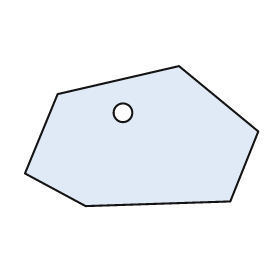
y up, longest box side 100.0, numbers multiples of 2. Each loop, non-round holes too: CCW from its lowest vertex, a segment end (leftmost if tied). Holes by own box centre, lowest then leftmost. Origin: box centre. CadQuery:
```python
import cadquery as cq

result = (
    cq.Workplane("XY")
    .moveTo(-24.0, -30.0)
    .lineTo(38.0, -28.0)
    .lineTo(50.0, 2.0)
    .lineTo(16.0, 30.0)
    .lineTo(-36.0, 18.0)
    .lineTo(-50.0, -16.0)
    .close()
    .moveTo(-8.0, 10.0)
    .circle(4.0)
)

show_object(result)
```